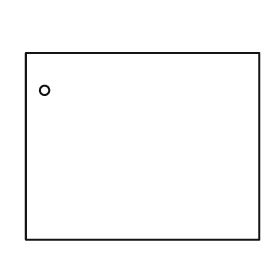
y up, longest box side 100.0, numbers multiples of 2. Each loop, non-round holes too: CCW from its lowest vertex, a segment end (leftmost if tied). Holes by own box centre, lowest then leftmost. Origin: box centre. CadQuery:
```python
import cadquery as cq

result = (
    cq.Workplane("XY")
    .moveTo(-50.0, -40.0)
    .lineTo(50.0, -40.0)
    .lineTo(50.0, 40.0)
    .lineTo(-50.0, 40.0)
    .close()
    .moveTo(-42.0, 24.0)
    .circle(2.0)
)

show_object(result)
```